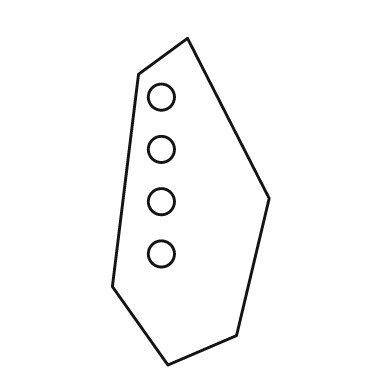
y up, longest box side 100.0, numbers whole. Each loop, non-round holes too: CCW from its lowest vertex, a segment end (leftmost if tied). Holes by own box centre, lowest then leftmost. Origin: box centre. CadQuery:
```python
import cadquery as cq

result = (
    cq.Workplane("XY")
    .moveTo(-7.0, -50.0)
    .lineTo(14.0, -41.0)
    .lineTo(24.0, 1.0)
    .lineTo(-1.0, 50.0)
    .lineTo(-16.0, 39.0)
    .lineTo(-24.0, -26.0)
    .close()
    .moveTo(-9.0, -16.0)
    .circle(4.0)
    .moveTo(-9.0, 0.0)
    .circle(4.0)
    .moveTo(-9.0, 16.0)
    .circle(4.0)
    .moveTo(-9.0, 32.0)
    .circle(4.0)
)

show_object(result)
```